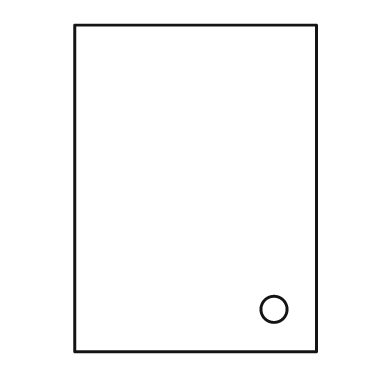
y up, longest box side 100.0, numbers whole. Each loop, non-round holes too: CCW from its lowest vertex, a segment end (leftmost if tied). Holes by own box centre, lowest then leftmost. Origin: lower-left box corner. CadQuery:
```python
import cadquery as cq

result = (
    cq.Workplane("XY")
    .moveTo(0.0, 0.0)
    .lineTo(74.0, 0.0)
    .lineTo(74.0, 100.0)
    .lineTo(0.0, 100.0)
    .close()
    .moveTo(61.0, 13.0)
    .circle(4.0)
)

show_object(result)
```